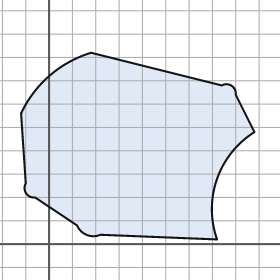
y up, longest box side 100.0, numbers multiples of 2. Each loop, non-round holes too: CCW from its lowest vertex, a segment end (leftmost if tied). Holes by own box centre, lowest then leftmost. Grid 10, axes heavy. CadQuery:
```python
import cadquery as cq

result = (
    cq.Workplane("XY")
    .moveTo(72.0, 2.0)
    .threePointArc((72.0, 28.0), (88.0, 48.0))
    .lineTo(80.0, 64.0)
    .threePointArc((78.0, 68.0), (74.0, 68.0))
    .lineTo(18.0, 82.0)
    .threePointArc((0.0, 72.0), (-12.0, 56.0))
    .lineTo(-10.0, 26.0)
    .threePointArc((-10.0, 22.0), (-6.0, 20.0))
    .lineTo(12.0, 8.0)
    .threePointArc((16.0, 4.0), (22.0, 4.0))
    .close()
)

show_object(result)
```